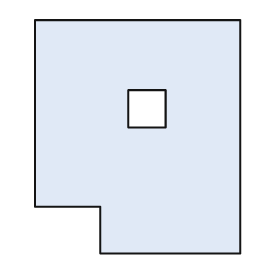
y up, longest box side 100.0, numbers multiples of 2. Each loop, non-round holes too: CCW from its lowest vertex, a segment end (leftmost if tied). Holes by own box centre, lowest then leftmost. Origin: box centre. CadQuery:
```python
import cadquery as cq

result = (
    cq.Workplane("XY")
    .moveTo(-16.0, -50.0)
    .lineTo(44.0, -50.0)
    .lineTo(44.0, 50.0)
    .lineTo(-44.0, 50.0)
    .lineTo(-44.0, -30.0)
    .lineTo(-16.0, -30.0)
    .close()
    .moveTo(-4.0, 4.0)
    .lineTo(12.0, 4.0)
    .lineTo(12.0, 20.0)
    .lineTo(-4.0, 20.0)
    .close()
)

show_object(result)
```